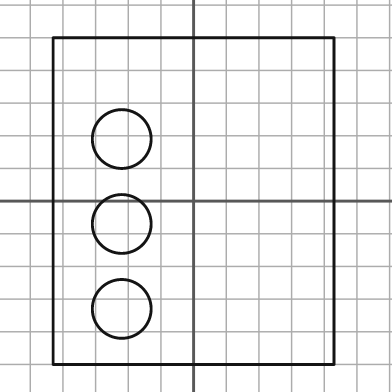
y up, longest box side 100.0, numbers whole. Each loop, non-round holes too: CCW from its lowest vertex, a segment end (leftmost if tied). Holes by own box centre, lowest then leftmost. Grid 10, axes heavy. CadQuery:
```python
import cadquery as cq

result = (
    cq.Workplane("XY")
    .moveTo(-43.0, -50.0)
    .lineTo(43.0, -50.0)
    .lineTo(43.0, 50.0)
    .lineTo(-43.0, 50.0)
    .close()
    .moveTo(-22.0, -33.0)
    .circle(9.0)
    .moveTo(-22.0, -7.0)
    .circle(9.0)
    .moveTo(-22.0, 19.0)
    .circle(9.0)
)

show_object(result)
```